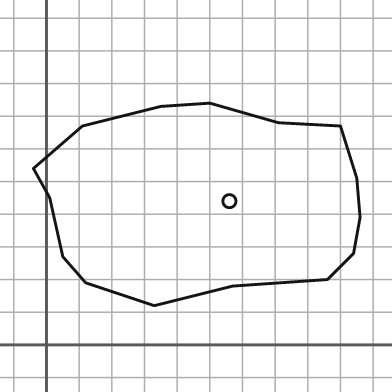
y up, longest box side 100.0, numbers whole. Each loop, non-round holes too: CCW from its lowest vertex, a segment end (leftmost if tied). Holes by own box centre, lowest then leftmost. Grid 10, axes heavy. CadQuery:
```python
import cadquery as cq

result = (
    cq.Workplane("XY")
    .moveTo(33.0, 12.0)
    .lineTo(57.0, 18.0)
    .lineTo(86.0, 20.0)
    .lineTo(94.0, 28.0)
    .lineTo(96.0, 39.0)
    .lineTo(95.0, 51.0)
    .lineTo(90.0, 67.0)
    .lineTo(71.0, 68.0)
    .lineTo(50.0, 74.0)
    .lineTo(35.0, 73.0)
    .lineTo(11.0, 67.0)
    .lineTo(-4.0, 54.0)
    .lineTo(1.0, 45.0)
    .lineTo(5.0, 27.0)
    .lineTo(12.0, 19.0)
    .close()
    .moveTo(56.0, 44.0)
    .circle(2.0)
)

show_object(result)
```